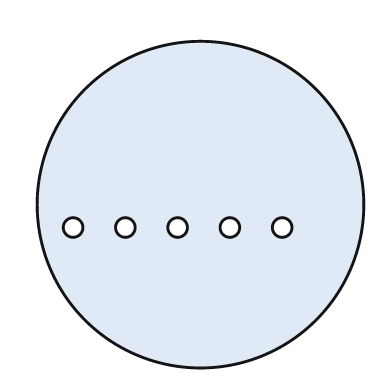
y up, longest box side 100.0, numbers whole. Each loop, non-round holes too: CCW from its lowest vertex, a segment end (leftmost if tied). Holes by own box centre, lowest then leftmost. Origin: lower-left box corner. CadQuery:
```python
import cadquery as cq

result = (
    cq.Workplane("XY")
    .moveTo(50.0, 50.0)
    .circle(50.0)
    .moveTo(11.0, 43.0)
    .circle(3.0)
    .moveTo(27.0, 43.0)
    .circle(3.0)
    .moveTo(43.0, 43.0)
    .circle(3.0)
    .moveTo(59.0, 43.0)
    .circle(3.0)
    .moveTo(75.0, 43.0)
    .circle(3.0)
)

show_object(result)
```